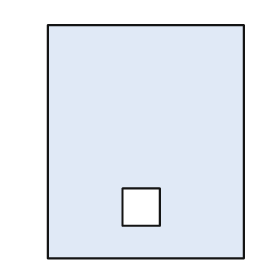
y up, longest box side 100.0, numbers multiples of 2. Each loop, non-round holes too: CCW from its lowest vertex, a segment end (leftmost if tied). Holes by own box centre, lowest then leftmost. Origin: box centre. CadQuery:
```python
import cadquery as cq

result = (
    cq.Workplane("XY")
    .moveTo(-42.0, -50.0)
    .lineTo(42.0, -50.0)
    .lineTo(42.0, 50.0)
    .lineTo(-42.0, 50.0)
    .close()
    .moveTo(-10.0, -36.0)
    .lineTo(6.0, -36.0)
    .lineTo(6.0, -20.0)
    .lineTo(-10.0, -20.0)
    .close()
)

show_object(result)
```